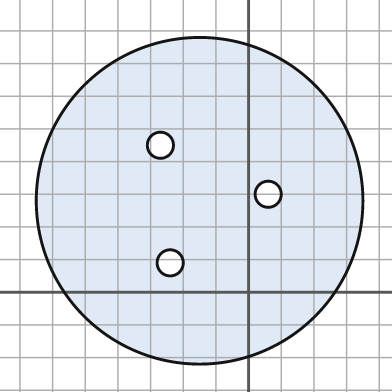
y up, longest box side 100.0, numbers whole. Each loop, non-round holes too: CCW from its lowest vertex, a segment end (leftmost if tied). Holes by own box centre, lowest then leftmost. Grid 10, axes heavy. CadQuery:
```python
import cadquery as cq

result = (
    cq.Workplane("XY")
    .moveTo(-15.0, 28.0)
    .circle(50.0)
    .moveTo(-24.0, 9.0)
    .circle(4.0)
    .moveTo(6.0, 30.0)
    .circle(4.0)
    .moveTo(-27.0, 45.0)
    .circle(4.0)
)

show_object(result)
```